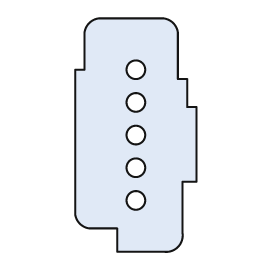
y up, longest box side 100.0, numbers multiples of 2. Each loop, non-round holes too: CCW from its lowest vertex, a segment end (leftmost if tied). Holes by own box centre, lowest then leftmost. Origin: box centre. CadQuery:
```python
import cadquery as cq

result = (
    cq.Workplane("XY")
    .moveTo(-8.0, -50.0)
    .lineTo(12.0, -50.0)
    .threePointArc((18.0, -48.0), (20.0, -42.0))
    .lineTo(20.0, -20.0)
    .lineTo(26.0, -20.0)
    .lineTo(26.0, 12.0)
    .lineTo(22.0, 12.0)
    .lineTo(22.0, 24.0)
    .lineTo(18.0, 24.0)
    .lineTo(18.0, 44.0)
    .threePointArc((16.0, 48.0), (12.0, 50.0))
    .lineTo(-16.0, 50.0)
    .threePointArc((-20.0, 48.0), (-22.0, 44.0))
    .lineTo(-22.0, 28.0)
    .lineTo(-26.0, 28.0)
    .lineTo(-26.0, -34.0)
    .threePointArc((-24.0, -38.0), (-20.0, -40.0))
    .lineTo(-8.0, -40.0)
    .close()
    .moveTo(0.0, -28.0)
    .circle(4.0)
    .moveTo(0.0, -14.0)
    .circle(4.0)
    .moveTo(0.0, 0.0)
    .circle(4.0)
    .moveTo(0.0, 14.0)
    .circle(4.0)
    .moveTo(0.0, 28.0)
    .circle(4.0)
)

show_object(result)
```